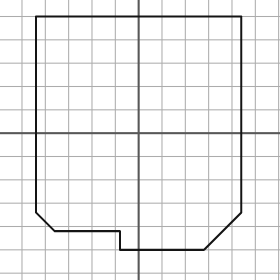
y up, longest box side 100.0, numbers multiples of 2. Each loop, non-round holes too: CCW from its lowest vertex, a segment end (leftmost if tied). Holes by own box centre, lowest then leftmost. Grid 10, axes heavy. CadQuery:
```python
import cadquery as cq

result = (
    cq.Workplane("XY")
    .moveTo(-8.0, -50.0)
    .lineTo(28.0, -50.0)
    .lineTo(44.0, -34.0)
    .lineTo(44.0, 50.0)
    .lineTo(-44.0, 50.0)
    .lineTo(-44.0, -34.0)
    .lineTo(-36.0, -42.0)
    .lineTo(-8.0, -42.0)
    .close()
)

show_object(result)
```